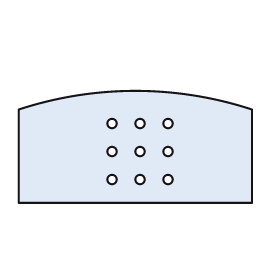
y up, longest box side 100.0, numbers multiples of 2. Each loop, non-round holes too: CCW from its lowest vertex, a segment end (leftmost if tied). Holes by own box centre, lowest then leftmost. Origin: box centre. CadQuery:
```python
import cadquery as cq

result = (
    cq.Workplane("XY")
    .moveTo(-50.0, -24.0)
    .lineTo(50.0, -24.0)
    .lineTo(50.0, 16.0)
    .threePointArc((0.0, 24.0), (-50.0, 16.0))
    .close()
    .moveTo(-10.0, -14.0)
    .circle(2.0)
    .moveTo(2.0, -14.0)
    .circle(2.0)
    .moveTo(14.0, -14.0)
    .circle(2.0)
    .moveTo(-10.0, -2.0)
    .circle(2.0)
    .moveTo(2.0, -2.0)
    .circle(2.0)
    .moveTo(14.0, -2.0)
    .circle(2.0)
    .moveTo(-10.0, 10.0)
    .circle(2.0)
    .moveTo(2.0, 10.0)
    .circle(2.0)
    .moveTo(14.0, 10.0)
    .circle(2.0)
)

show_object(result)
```